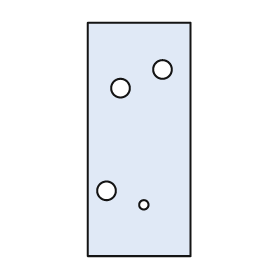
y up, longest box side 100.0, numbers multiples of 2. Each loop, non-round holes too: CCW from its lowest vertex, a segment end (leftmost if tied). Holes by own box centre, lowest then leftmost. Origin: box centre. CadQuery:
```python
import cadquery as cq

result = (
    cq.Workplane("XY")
    .moveTo(-22.0, -50.0)
    .lineTo(22.0, -50.0)
    .lineTo(22.0, 50.0)
    .lineTo(-22.0, 50.0)
    .close()
    .moveTo(2.0, -28.0)
    .circle(2.0)
    .moveTo(-14.0, -22.0)
    .circle(4.0)
    .moveTo(-8.0, 22.0)
    .circle(4.0)
    .moveTo(10.0, 30.0)
    .circle(4.0)
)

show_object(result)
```